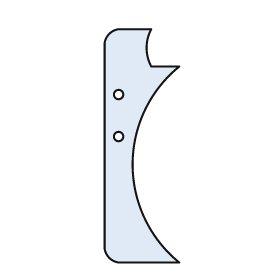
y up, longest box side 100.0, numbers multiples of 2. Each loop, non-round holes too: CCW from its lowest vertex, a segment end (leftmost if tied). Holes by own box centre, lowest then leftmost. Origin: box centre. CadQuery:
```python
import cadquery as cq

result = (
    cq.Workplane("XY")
    .moveTo(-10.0, -50.0)
    .lineTo(16.0, -50.0)
    .threePointArc((-4.0, -8.0), (16.0, 34.0))
    .lineTo(4.0, 34.0)
    .threePointArc((2.0, 42.0), (4.0, 50.0))
    .lineTo(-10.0, 50.0)
    .threePointArc((-14.0, 48.0), (-16.0, 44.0))
    .lineTo(-16.0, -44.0)
    .threePointArc((-14.0, -48.0), (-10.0, -50.0))
    .close()
    .moveTo(-10.0, 4.0)
    .circle(2.0)
    .moveTo(-10.0, 22.0)
    .circle(2.0)
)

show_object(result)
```